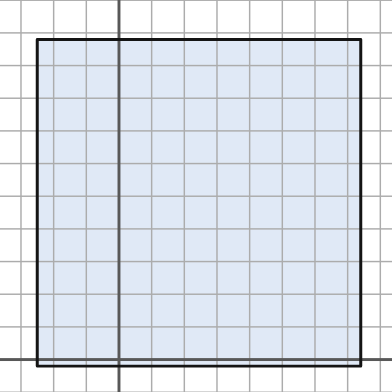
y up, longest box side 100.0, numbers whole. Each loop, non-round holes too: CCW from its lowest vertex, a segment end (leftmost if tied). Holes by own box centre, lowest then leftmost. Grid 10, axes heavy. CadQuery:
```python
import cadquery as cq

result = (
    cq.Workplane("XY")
    .moveTo(-25.0, -2.0)
    .lineTo(74.0, -2.0)
    .lineTo(74.0, 98.0)
    .lineTo(-25.0, 98.0)
    .close()
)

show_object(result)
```